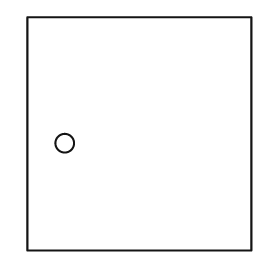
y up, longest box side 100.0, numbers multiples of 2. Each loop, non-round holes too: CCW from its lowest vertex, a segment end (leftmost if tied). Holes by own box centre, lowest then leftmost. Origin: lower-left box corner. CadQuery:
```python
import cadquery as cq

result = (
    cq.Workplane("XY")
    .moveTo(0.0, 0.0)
    .lineTo(96.0, 0.0)
    .lineTo(96.0, 100.0)
    .lineTo(0.0, 100.0)
    .close()
    .moveTo(16.0, 46.0)
    .circle(4.0)
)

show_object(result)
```